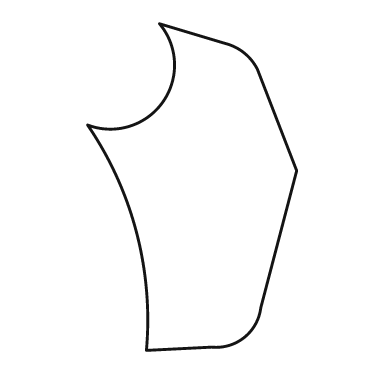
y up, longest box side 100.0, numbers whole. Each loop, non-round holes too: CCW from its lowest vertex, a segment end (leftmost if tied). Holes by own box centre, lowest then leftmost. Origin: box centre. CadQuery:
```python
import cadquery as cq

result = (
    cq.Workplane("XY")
    .moveTo(-14.0, -50.0)
    .lineTo(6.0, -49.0)
    .threePointArc((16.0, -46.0), (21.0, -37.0))
    .lineTo(32.0, 5.0)
    .lineTo(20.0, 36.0)
    .threePointArc((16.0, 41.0), (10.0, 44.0))
    .lineTo(-10.0, 50.0)
    .threePointArc((-9.0, 26.0), (-32.0, 19.0))
    .threePointArc((-17.0, -14.0), (-14.0, -50.0))
    .close()
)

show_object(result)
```